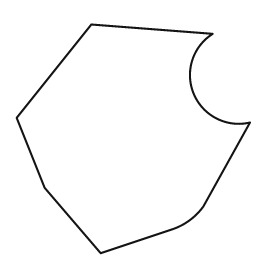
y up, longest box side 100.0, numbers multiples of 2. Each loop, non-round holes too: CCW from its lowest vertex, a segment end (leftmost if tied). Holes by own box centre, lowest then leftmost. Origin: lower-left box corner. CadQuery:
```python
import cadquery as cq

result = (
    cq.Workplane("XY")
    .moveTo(36.0, 0.0)
    .lineTo(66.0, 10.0)
    .threePointArc((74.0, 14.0), (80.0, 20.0))
    .lineTo(100.0, 56.0)
    .threePointArc((76.0, 68.0), (84.0, 94.0))
    .lineTo(32.0, 98.0)
    .lineTo(0.0, 58.0)
    .lineTo(12.0, 28.0)
    .close()
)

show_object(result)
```